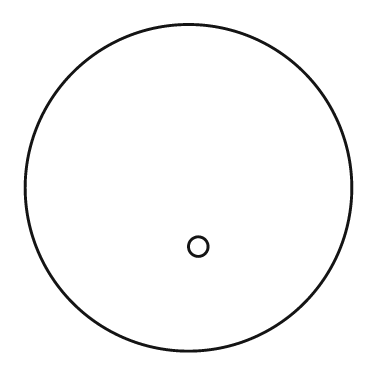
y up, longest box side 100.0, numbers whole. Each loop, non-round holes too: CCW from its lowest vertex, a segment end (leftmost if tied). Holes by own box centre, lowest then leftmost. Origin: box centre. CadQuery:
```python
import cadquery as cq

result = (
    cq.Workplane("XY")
    .moveTo(0.0, 0.0)
    .circle(50.0)
    .moveTo(3.0, -18.0)
    .circle(3.0)
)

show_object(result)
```